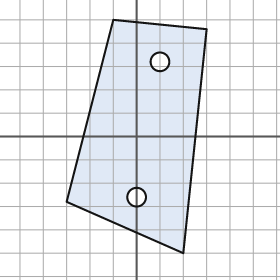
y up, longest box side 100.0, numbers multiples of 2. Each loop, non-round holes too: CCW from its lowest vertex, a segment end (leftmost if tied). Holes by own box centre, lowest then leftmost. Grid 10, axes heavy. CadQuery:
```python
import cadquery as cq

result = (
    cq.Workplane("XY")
    .moveTo(20.0, -50.0)
    .lineTo(30.0, 46.0)
    .lineTo(-10.0, 50.0)
    .lineTo(-30.0, -28.0)
    .close()
    .moveTo(0.0, -26.0)
    .circle(4.0)
    .moveTo(10.0, 32.0)
    .circle(4.0)
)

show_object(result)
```